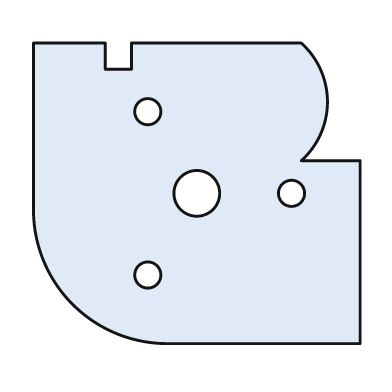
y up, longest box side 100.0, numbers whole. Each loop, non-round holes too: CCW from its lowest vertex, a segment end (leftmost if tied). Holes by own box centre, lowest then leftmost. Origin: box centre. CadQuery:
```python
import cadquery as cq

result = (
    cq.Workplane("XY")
    .moveTo(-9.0, -46.0)
    .lineTo(50.0, -46.0)
    .lineTo(50.0, 10.0)
    .lineTo(32.0, 10.0)
    .threePointArc((40.0, 28.0), (32.0, 46.0))
    .lineTo(-20.0, 46.0)
    .lineTo(-20.0, 38.0)
    .lineTo(-28.0, 38.0)
    .lineTo(-28.0, 46.0)
    .lineTo(-50.0, 46.0)
    .lineTo(-50.0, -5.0)
    .threePointArc((-38.0, -34.0), (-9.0, -46.0))
    .close()
    .moveTo(-15.0, -25.0)
    .circle(4.0)
    .moveTo(0.0, 0.0)
    .circle(7.0)
    .moveTo(29.0, 0.0)
    .circle(4.0)
    .moveTo(-15.0, 25.0)
    .circle(4.0)
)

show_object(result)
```